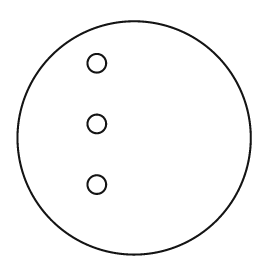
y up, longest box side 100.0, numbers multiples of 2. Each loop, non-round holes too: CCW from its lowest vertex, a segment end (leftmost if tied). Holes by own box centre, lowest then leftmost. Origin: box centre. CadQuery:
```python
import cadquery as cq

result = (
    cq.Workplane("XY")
    .moveTo(0.0, 0.0)
    .circle(50.0)
    .moveTo(-16.0, -20.0)
    .circle(4.0)
    .moveTo(-16.0, 6.0)
    .circle(4.0)
    .moveTo(-16.0, 32.0)
    .circle(4.0)
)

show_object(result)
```